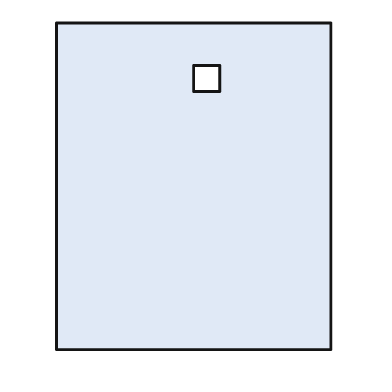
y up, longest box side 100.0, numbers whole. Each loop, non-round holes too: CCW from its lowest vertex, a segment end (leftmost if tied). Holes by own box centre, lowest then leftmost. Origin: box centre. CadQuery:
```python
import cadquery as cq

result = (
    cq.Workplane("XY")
    .moveTo(-42.0, -50.0)
    .lineTo(42.0, -50.0)
    .lineTo(42.0, 50.0)
    .lineTo(-42.0, 50.0)
    .close()
    .moveTo(0.0, 29.0)
    .lineTo(8.0, 29.0)
    .lineTo(8.0, 37.0)
    .lineTo(0.0, 37.0)
    .close()
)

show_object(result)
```